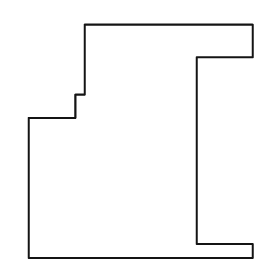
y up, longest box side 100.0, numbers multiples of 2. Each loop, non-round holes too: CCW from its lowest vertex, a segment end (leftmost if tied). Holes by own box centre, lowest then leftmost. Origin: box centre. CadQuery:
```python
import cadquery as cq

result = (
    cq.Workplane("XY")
    .moveTo(-48.0, -50.0)
    .lineTo(48.0, -50.0)
    .lineTo(48.0, -44.0)
    .lineTo(24.0, -44.0)
    .lineTo(24.0, 36.0)
    .lineTo(48.0, 36.0)
    .lineTo(48.0, 50.0)
    .lineTo(-24.0, 50.0)
    .lineTo(-24.0, 20.0)
    .lineTo(-28.0, 20.0)
    .lineTo(-28.0, 10.0)
    .lineTo(-48.0, 10.0)
    .close()
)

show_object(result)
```